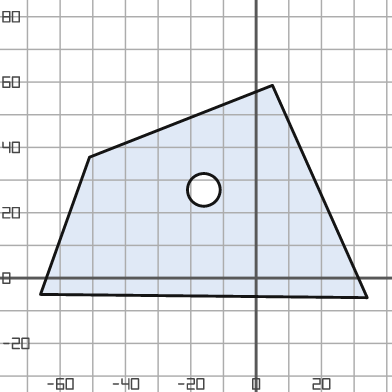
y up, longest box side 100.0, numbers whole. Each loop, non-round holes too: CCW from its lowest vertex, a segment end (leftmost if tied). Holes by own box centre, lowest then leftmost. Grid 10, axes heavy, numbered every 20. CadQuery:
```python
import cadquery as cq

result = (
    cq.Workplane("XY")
    .moveTo(34.0, -6.0)
    .lineTo(5.0, 59.0)
    .lineTo(-51.0, 37.0)
    .lineTo(-66.0, -5.0)
    .close()
    .moveTo(-16.0, 27.0)
    .circle(5.0)
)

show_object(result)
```